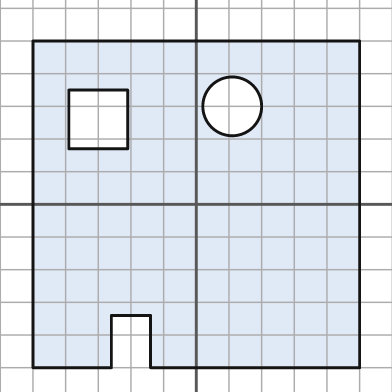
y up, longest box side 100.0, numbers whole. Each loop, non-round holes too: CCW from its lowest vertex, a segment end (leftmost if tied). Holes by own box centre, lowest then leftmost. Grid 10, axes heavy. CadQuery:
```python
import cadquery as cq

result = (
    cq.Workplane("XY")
    .moveTo(-50.0, -50.0)
    .lineTo(-26.0, -50.0)
    .lineTo(-26.0, -34.0)
    .lineTo(-14.0, -34.0)
    .lineTo(-14.0, -50.0)
    .lineTo(50.0, -50.0)
    .lineTo(50.0, 50.0)
    .lineTo(-50.0, 50.0)
    .close()
    .moveTo(-39.0, 17.0)
    .lineTo(-21.0, 17.0)
    .lineTo(-21.0, 35.0)
    .lineTo(-39.0, 35.0)
    .close()
    .moveTo(11.0, 30.0)
    .circle(9.0)
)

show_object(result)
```